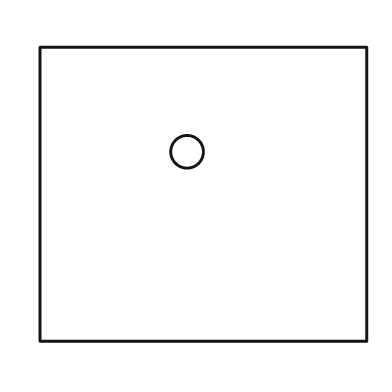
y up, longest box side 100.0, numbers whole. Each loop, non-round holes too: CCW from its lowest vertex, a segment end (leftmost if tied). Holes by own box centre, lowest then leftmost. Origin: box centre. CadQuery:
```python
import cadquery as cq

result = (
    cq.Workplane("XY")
    .moveTo(-50.0, -45.0)
    .lineTo(50.0, -45.0)
    .lineTo(50.0, 45.0)
    .lineTo(-50.0, 45.0)
    .close()
    .moveTo(-5.0, 13.0)
    .circle(5.0)
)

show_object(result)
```